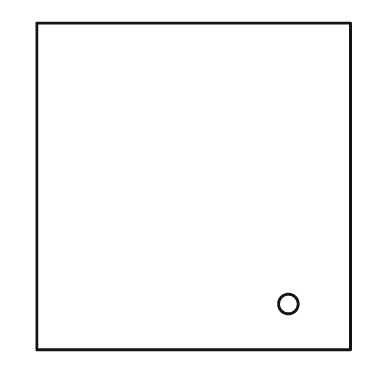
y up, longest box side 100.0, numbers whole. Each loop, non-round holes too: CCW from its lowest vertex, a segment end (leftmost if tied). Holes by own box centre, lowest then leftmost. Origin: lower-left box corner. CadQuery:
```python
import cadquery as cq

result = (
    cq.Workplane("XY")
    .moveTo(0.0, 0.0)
    .lineTo(96.0, 0.0)
    .lineTo(96.0, 100.0)
    .lineTo(0.0, 100.0)
    .close()
    .moveTo(77.0, 14.0)
    .circle(3.0)
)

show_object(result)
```